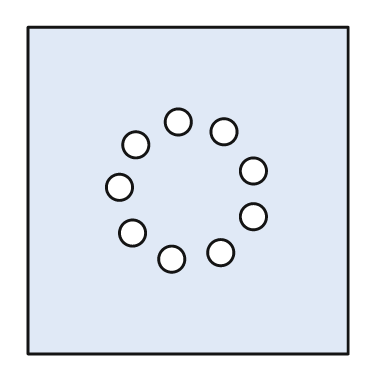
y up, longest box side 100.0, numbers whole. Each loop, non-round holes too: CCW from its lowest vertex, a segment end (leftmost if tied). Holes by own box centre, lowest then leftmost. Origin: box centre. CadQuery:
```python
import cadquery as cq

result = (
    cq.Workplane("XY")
    .moveTo(-49.0, -50.0)
    .lineTo(49.0, -50.0)
    .lineTo(49.0, 50.0)
    .lineTo(-49.0, 50.0)
    .close()
    .moveTo(-5.0, -21.0)
    .circle(4.0)
    .moveTo(10.0, -19.0)
    .circle(4.0)
    .moveTo(-17.0, -13.0)
    .circle(4.0)
    .moveTo(20.0, -8.0)
    .circle(4.0)
    .moveTo(-21.0, 1.0)
    .circle(4.0)
    .moveTo(20.0, 6.0)
    .circle(4.0)
    .moveTo(-16.0, 14.0)
    .circle(4.0)
    .moveTo(11.0, 18.0)
    .circle(4.0)
    .moveTo(-3.0, 21.0)
    .circle(4.0)
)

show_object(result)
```